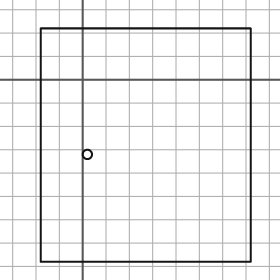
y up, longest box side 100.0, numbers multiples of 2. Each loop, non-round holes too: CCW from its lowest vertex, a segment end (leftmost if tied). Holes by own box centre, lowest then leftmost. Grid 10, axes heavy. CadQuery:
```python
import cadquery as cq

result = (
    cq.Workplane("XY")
    .moveTo(-18.0, -78.0)
    .lineTo(72.0, -78.0)
    .lineTo(72.0, 22.0)
    .lineTo(-18.0, 22.0)
    .close()
    .moveTo(2.0, -32.0)
    .circle(2.0)
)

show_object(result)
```